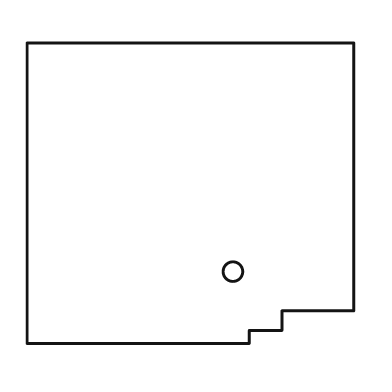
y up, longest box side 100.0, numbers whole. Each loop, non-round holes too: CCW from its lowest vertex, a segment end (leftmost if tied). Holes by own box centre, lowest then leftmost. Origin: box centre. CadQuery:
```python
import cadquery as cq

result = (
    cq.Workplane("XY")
    .moveTo(-50.0, -46.0)
    .lineTo(18.0, -46.0)
    .lineTo(18.0, -42.0)
    .lineTo(28.0, -42.0)
    .lineTo(28.0, -36.0)
    .lineTo(50.0, -36.0)
    .lineTo(50.0, 46.0)
    .lineTo(-50.0, 46.0)
    .close()
    .moveTo(13.0, -24.0)
    .circle(3.0)
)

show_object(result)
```